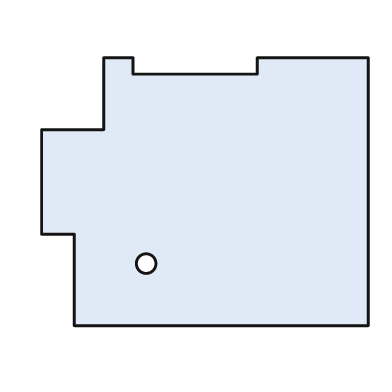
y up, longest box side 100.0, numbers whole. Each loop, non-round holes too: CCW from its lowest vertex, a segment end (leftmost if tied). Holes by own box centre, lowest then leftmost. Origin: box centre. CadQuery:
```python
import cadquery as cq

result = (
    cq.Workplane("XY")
    .moveTo(-40.0, -41.0)
    .lineTo(50.0, -41.0)
    .lineTo(50.0, 41.0)
    .lineTo(16.0, 41.0)
    .lineTo(16.0, 36.0)
    .lineTo(-22.0, 36.0)
    .lineTo(-22.0, 41.0)
    .lineTo(-31.0, 41.0)
    .lineTo(-31.0, 19.0)
    .lineTo(-50.0, 19.0)
    .lineTo(-50.0, -13.0)
    .lineTo(-40.0, -13.0)
    .close()
    .moveTo(-18.0, -22.0)
    .circle(3.0)
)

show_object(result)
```